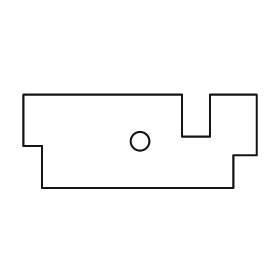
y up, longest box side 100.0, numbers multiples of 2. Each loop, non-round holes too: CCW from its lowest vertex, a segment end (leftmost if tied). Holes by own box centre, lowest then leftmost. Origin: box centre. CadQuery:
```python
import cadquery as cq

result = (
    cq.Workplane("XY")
    .moveTo(-42.0, -20.0)
    .lineTo(40.0, -20.0)
    .lineTo(40.0, -6.0)
    .lineTo(50.0, -6.0)
    .lineTo(50.0, 20.0)
    .lineTo(30.0, 20.0)
    .lineTo(30.0, 2.0)
    .lineTo(18.0, 2.0)
    .lineTo(18.0, 20.0)
    .lineTo(-50.0, 20.0)
    .lineTo(-50.0, -2.0)
    .lineTo(-42.0, -2.0)
    .close()
    .moveTo(0.0, 0.0)
    .circle(4.0)
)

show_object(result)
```